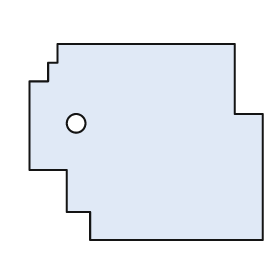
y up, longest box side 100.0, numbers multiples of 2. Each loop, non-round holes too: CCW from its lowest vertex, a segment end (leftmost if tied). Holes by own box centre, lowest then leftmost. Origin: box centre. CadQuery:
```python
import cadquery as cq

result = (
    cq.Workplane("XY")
    .moveTo(-24.0, -42.0)
    .lineTo(50.0, -42.0)
    .lineTo(50.0, 12.0)
    .lineTo(38.0, 12.0)
    .lineTo(38.0, 42.0)
    .lineTo(-38.0, 42.0)
    .lineTo(-38.0, 34.0)
    .lineTo(-42.0, 34.0)
    .lineTo(-42.0, 26.0)
    .lineTo(-50.0, 26.0)
    .lineTo(-50.0, -12.0)
    .lineTo(-34.0, -12.0)
    .lineTo(-34.0, -30.0)
    .lineTo(-24.0, -30.0)
    .close()
    .moveTo(-30.0, 8.0)
    .circle(4.0)
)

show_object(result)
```